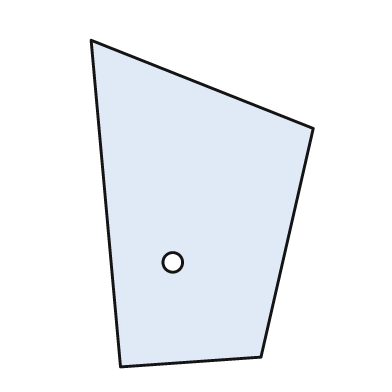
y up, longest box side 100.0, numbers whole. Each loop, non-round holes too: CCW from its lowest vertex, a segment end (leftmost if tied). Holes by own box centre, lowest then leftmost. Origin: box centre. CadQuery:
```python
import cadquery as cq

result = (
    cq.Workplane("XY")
    .moveTo(-25.0, -50.0)
    .lineTo(18.0, -47.0)
    .lineTo(34.0, 23.0)
    .lineTo(-34.0, 50.0)
    .close()
    .moveTo(-9.0, -18.0)
    .circle(3.0)
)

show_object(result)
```